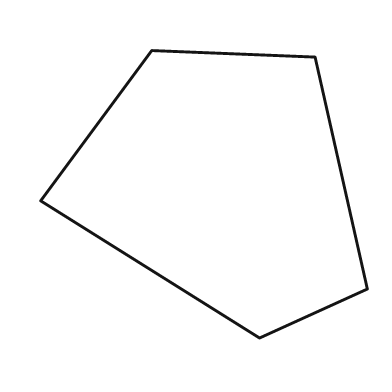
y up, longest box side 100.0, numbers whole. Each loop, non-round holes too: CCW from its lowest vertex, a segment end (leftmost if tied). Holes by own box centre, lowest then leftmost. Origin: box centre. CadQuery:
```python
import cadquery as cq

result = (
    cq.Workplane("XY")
    .moveTo(17.0, -44.0)
    .lineTo(50.0, -29.0)
    .lineTo(34.0, 42.0)
    .lineTo(-16.0, 44.0)
    .lineTo(-50.0, -2.0)
    .close()
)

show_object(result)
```